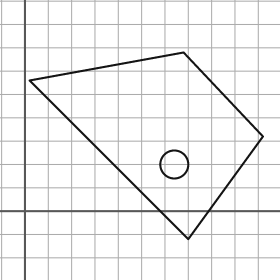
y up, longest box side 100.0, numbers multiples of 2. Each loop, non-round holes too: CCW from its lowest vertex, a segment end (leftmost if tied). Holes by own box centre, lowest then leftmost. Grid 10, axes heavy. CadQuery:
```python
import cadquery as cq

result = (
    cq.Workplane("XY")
    .moveTo(70.0, -12.0)
    .lineTo(102.0, 32.0)
    .lineTo(68.0, 68.0)
    .lineTo(2.0, 56.0)
    .close()
    .moveTo(64.0, 20.0)
    .circle(6.0)
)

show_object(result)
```